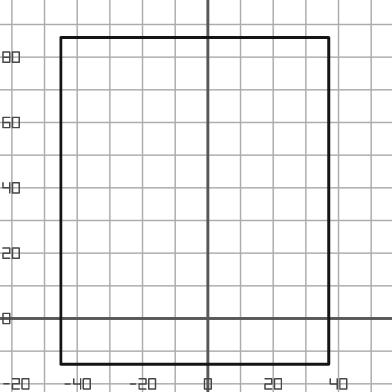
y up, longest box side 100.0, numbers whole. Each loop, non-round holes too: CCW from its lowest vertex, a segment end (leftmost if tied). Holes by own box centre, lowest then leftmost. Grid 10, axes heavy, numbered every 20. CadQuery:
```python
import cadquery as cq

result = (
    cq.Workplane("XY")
    .moveTo(-45.0, -14.0)
    .lineTo(37.0, -14.0)
    .lineTo(37.0, 86.0)
    .lineTo(-45.0, 86.0)
    .close()
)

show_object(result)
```